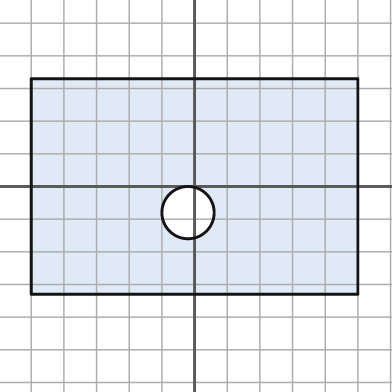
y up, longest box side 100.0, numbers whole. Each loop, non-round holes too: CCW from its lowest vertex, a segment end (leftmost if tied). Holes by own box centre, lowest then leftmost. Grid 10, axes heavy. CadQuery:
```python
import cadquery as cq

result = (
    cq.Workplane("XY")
    .moveTo(-50.0, -33.0)
    .lineTo(50.0, -33.0)
    .lineTo(50.0, 33.0)
    .lineTo(-50.0, 33.0)
    .close()
    .moveTo(-2.0, -8.0)
    .circle(8.0)
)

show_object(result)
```